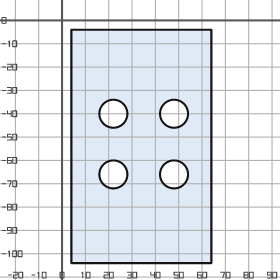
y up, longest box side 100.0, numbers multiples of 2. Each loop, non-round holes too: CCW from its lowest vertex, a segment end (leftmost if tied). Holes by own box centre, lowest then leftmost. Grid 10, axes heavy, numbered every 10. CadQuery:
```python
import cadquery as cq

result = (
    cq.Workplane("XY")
    .moveTo(4.0, -104.0)
    .lineTo(64.0, -104.0)
    .lineTo(64.0, -4.0)
    .lineTo(4.0, -4.0)
    .close()
    .moveTo(22.0, -66.0)
    .circle(6.0)
    .moveTo(48.0, -66.0)
    .circle(6.0)
    .moveTo(22.0, -40.0)
    .circle(6.0)
    .moveTo(48.0, -40.0)
    .circle(6.0)
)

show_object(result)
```